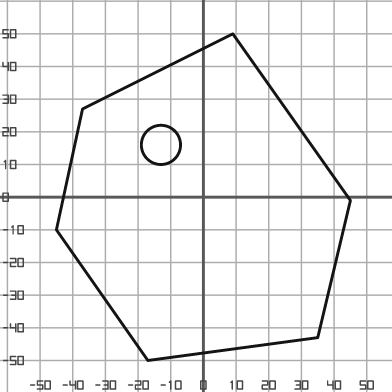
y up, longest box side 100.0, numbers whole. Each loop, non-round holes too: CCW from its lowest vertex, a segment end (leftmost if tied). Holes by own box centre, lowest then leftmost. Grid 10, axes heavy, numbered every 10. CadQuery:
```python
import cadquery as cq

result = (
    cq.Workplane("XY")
    .moveTo(-17.0, -50.0)
    .lineTo(35.0, -43.0)
    .lineTo(45.0, -1.0)
    .lineTo(9.0, 50.0)
    .lineTo(-37.0, 27.0)
    .lineTo(-45.0, -10.0)
    .close()
    .moveTo(-13.0, 16.0)
    .circle(6.0)
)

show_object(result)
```